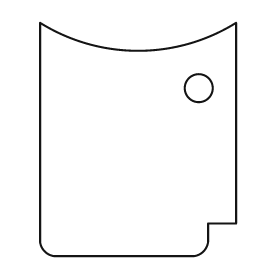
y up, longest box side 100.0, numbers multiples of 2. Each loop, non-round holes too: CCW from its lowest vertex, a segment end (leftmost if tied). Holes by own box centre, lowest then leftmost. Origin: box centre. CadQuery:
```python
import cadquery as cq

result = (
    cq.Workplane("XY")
    .moveTo(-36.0, -50.0)
    .lineTo(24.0, -50.0)
    .threePointArc((28.0, -48.0), (30.0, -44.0))
    .lineTo(30.0, -36.0)
    .lineTo(42.0, -36.0)
    .lineTo(42.0, 50.0)
    .threePointArc((0.0, 38.0), (-42.0, 50.0))
    .lineTo(-42.0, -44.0)
    .threePointArc((-40.0, -48.0), (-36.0, -50.0))
    .close()
    .moveTo(26.0, 22.0)
    .circle(6.0)
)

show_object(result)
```